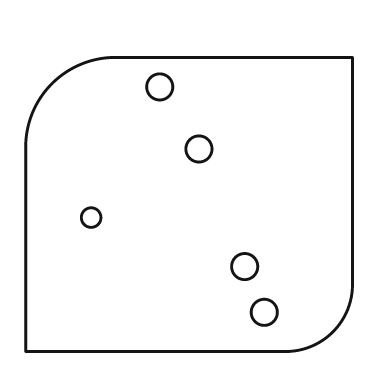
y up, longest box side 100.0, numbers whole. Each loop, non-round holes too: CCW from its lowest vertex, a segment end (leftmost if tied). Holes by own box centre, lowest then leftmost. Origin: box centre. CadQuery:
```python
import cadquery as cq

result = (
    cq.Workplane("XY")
    .moveTo(-50.0, -45.0)
    .lineTo(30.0, -45.0)
    .threePointArc((44.0, -39.0), (50.0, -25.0))
    .lineTo(50.0, 45.0)
    .lineTo(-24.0, 45.0)
    .threePointArc((-42.0, 37.0), (-50.0, 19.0))
    .close()
    .moveTo(23.0, -33.0)
    .circle(4.0)
    .moveTo(17.0, -19.0)
    .circle(4.0)
    .moveTo(-30.0, -4.0)
    .circle(3.0)
    .moveTo(3.0, 17.0)
    .circle(4.0)
    .moveTo(-9.0, 36.0)
    .circle(4.0)
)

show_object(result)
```